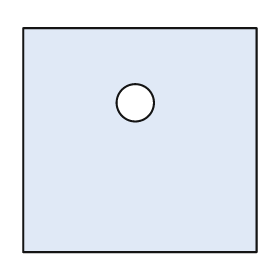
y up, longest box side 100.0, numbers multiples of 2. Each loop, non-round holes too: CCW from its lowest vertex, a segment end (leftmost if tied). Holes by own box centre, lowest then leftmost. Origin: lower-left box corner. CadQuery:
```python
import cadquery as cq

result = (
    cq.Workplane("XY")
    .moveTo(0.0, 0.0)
    .lineTo(100.0, 0.0)
    .lineTo(100.0, 96.0)
    .lineTo(0.0, 96.0)
    .close()
    .moveTo(48.0, 64.0)
    .circle(8.0)
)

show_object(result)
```